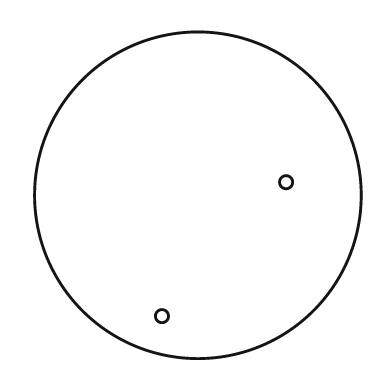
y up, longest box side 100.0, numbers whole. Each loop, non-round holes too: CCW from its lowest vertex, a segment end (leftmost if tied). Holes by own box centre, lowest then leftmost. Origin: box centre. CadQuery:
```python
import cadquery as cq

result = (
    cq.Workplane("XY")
    .moveTo(0.0, 0.0)
    .circle(50.0)
    .moveTo(-11.0, -37.0)
    .circle(2.0)
    .moveTo(27.0, 4.0)
    .circle(2.0)
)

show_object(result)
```